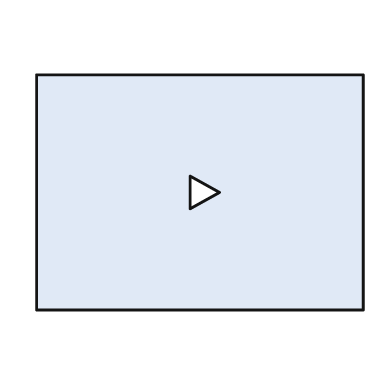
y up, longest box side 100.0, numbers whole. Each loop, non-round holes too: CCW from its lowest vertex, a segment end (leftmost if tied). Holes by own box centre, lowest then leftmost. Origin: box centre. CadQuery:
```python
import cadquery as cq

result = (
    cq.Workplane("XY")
    .moveTo(-50.0, -36.0)
    .lineTo(50.0, -36.0)
    .lineTo(50.0, 36.0)
    .lineTo(-50.0, 36.0)
    .close()
    .moveTo(-3.0, -5.0)
    .lineTo(6.0, 0.0)
    .lineTo(-3.0, 5.0)
    .close()
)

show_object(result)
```